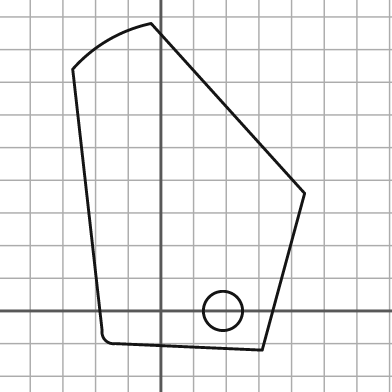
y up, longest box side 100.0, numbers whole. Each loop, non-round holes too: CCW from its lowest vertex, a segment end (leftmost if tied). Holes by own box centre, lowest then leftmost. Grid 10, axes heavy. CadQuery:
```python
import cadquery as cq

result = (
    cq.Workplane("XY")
    .moveTo(31.0, -12.0)
    .lineTo(44.0, 36.0)
    .lineTo(-3.0, 88.0)
    .threePointArc((-16.0, 83.0), (-27.0, 74.0))
    .lineTo(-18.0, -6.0)
    .threePointArc((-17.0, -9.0), (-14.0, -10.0))
    .close()
    .moveTo(19.0, 0.0)
    .circle(6.0)
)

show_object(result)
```